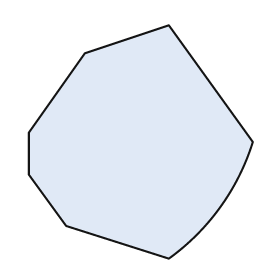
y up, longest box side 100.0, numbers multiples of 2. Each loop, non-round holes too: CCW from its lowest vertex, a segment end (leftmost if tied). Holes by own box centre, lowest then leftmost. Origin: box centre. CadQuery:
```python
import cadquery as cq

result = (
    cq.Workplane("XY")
    .moveTo(12.0, -50.0)
    .threePointArc((34.0, -28.0), (48.0, 0.0))
    .lineTo(12.0, 50.0)
    .lineTo(-24.0, 38.0)
    .lineTo(-48.0, 4.0)
    .lineTo(-48.0, -14.0)
    .lineTo(-32.0, -36.0)
    .close()
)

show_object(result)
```